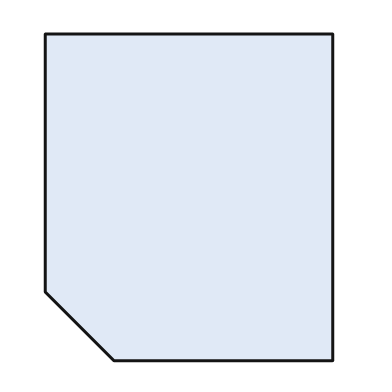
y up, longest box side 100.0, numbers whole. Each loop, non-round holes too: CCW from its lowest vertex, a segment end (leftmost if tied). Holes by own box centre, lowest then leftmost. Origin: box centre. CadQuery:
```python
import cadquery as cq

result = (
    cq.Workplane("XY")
    .moveTo(-23.0, -50.0)
    .lineTo(44.0, -50.0)
    .lineTo(44.0, 50.0)
    .lineTo(-44.0, 50.0)
    .lineTo(-44.0, -29.0)
    .close()
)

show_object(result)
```